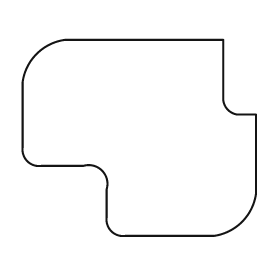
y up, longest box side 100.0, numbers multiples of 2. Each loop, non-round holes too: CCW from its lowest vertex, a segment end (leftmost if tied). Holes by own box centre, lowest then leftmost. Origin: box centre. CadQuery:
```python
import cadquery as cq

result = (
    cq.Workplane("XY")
    .moveTo(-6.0, -42.0)
    .lineTo(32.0, -42.0)
    .threePointArc((44.0, -36.0), (50.0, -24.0))
    .lineTo(50.0, 10.0)
    .lineTo(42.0, 10.0)
    .threePointArc((38.0, 12.0), (36.0, 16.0))
    .lineTo(36.0, 42.0)
    .lineTo(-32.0, 42.0)
    .threePointArc((-44.0, 36.0), (-50.0, 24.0))
    .lineTo(-50.0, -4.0)
    .threePointArc((-48.0, -10.0), (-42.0, -12.0))
    .lineTo(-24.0, -12.0)
    .threePointArc((-16.0, -14.0), (-14.0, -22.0))
    .lineTo(-14.0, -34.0)
    .threePointArc((-12.0, -40.0), (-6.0, -42.0))
    .close()
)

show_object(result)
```